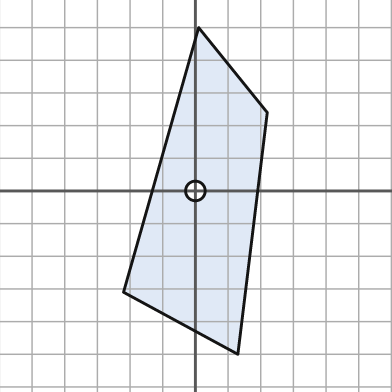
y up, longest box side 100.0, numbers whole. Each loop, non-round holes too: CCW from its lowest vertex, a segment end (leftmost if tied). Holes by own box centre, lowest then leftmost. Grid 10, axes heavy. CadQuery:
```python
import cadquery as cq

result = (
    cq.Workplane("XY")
    .moveTo(13.0, -50.0)
    .lineTo(22.0, 24.0)
    .lineTo(1.0, 50.0)
    .lineTo(-22.0, -31.0)
    .close()
    .moveTo(0.0, 0.0)
    .circle(3.0)
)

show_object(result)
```